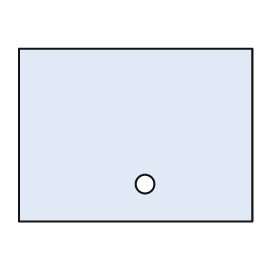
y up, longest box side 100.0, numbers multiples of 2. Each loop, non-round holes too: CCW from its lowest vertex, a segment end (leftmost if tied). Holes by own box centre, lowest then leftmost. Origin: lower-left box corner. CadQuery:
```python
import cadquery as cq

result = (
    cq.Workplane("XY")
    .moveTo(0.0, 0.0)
    .lineTo(100.0, 0.0)
    .lineTo(100.0, 74.0)
    .lineTo(0.0, 74.0)
    .close()
    .moveTo(54.0, 16.0)
    .circle(4.0)
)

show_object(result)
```